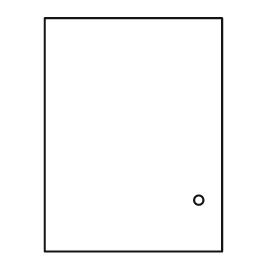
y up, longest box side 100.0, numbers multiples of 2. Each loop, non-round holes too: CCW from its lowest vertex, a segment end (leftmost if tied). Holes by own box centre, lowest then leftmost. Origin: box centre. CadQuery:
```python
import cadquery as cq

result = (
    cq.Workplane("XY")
    .moveTo(-38.0, -50.0)
    .lineTo(38.0, -50.0)
    .lineTo(38.0, 50.0)
    .lineTo(-38.0, 50.0)
    .close()
    .moveTo(28.0, -28.0)
    .circle(2.0)
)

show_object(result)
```